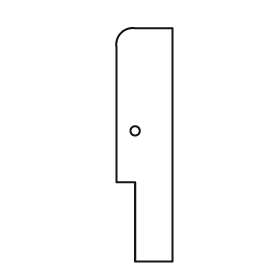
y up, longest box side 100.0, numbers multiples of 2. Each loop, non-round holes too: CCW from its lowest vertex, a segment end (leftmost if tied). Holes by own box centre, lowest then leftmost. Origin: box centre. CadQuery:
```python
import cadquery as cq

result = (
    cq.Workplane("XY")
    .moveTo(-4.0, -50.0)
    .lineTo(12.0, -50.0)
    .lineTo(12.0, 50.0)
    .lineTo(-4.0, 50.0)
    .threePointArc((-10.0, 48.0), (-12.0, 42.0))
    .lineTo(-12.0, -16.0)
    .lineTo(-4.0, -16.0)
    .close()
    .moveTo(-4.0, 6.0)
    .circle(2.0)
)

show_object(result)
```